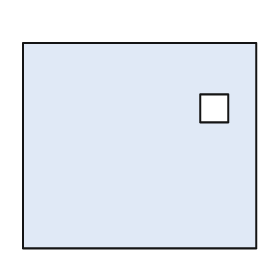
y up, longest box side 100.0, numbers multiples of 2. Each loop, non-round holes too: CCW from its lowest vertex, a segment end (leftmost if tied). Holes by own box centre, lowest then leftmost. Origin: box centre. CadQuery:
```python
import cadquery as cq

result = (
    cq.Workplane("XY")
    .moveTo(-50.0, -44.0)
    .lineTo(50.0, -44.0)
    .lineTo(50.0, 44.0)
    .lineTo(-50.0, 44.0)
    .close()
    .moveTo(26.0, 10.0)
    .lineTo(38.0, 10.0)
    .lineTo(38.0, 22.0)
    .lineTo(26.0, 22.0)
    .close()
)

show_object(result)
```